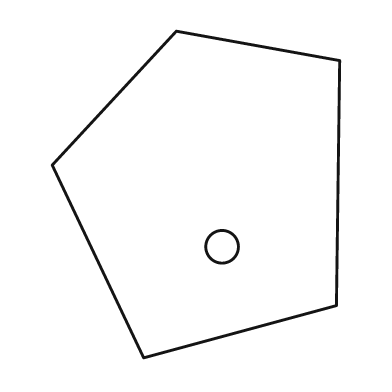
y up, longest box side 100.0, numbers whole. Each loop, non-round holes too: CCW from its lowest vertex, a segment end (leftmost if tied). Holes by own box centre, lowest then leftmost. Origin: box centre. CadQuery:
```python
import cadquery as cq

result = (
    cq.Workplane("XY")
    .moveTo(-16.0, -50.0)
    .lineTo(43.0, -34.0)
    .lineTo(44.0, 41.0)
    .lineTo(-6.0, 50.0)
    .lineTo(-44.0, 9.0)
    .close()
    .moveTo(8.0, -16.0)
    .circle(5.0)
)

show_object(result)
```